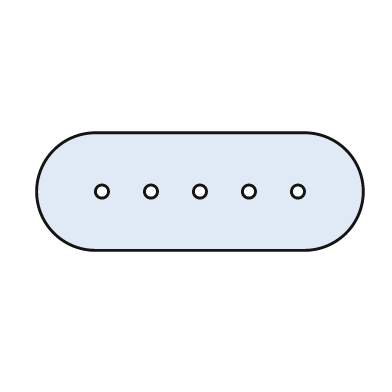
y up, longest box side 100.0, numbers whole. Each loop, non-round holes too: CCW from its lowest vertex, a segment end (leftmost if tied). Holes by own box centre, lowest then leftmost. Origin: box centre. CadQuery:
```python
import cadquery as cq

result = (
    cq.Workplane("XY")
    .moveTo(-32.0, -18.0)
    .lineTo(32.0, -18.0)
    .threePointArc((50.0, 0.0), (32.0, 18.0))
    .lineTo(-32.0, 18.0)
    .threePointArc((-50.0, 0.0), (-32.0, -18.0))
    .close()
    .moveTo(-30.0, 0.0)
    .circle(2.0)
    .moveTo(-15.0, 0.0)
    .circle(2.0)
    .moveTo(0.0, 0.0)
    .circle(2.0)
    .moveTo(15.0, 0.0)
    .circle(2.0)
    .moveTo(30.0, 0.0)
    .circle(2.0)
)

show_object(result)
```